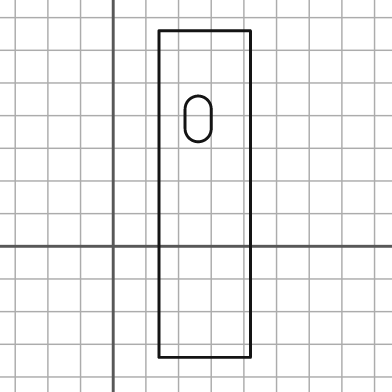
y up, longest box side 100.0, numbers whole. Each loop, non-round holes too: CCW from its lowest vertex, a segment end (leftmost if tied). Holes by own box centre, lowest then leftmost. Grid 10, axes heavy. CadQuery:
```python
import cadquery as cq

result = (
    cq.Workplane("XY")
    .moveTo(14.0, -34.0)
    .lineTo(42.0, -34.0)
    .lineTo(42.0, 66.0)
    .lineTo(14.0, 66.0)
    .close()
    .moveTo(22.0, 36.0)
    .threePointArc((26.0, 32.0), (30.0, 36.0))
    .lineTo(30.0, 42.0)
    .threePointArc((26.0, 46.0), (22.0, 42.0))
    .close()
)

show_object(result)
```